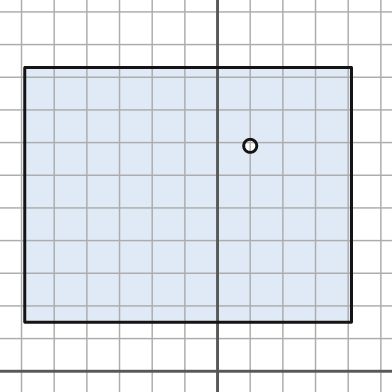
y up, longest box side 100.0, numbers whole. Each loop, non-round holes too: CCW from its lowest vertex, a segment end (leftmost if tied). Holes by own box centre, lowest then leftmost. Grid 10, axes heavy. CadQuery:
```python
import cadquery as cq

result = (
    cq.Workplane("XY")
    .moveTo(-59.0, 15.0)
    .lineTo(41.0, 15.0)
    .lineTo(41.0, 93.0)
    .lineTo(-59.0, 93.0)
    .close()
    .moveTo(10.0, 69.0)
    .circle(2.0)
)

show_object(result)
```